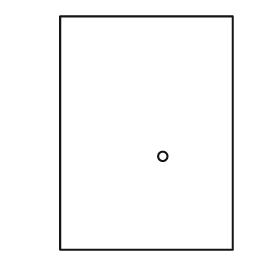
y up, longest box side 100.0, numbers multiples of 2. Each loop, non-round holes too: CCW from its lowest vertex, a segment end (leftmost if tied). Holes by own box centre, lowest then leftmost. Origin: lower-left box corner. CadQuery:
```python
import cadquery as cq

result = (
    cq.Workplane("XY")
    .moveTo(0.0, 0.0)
    .lineTo(74.0, 0.0)
    .lineTo(74.0, 100.0)
    .lineTo(0.0, 100.0)
    .close()
    .moveTo(44.0, 40.0)
    .circle(2.0)
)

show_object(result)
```